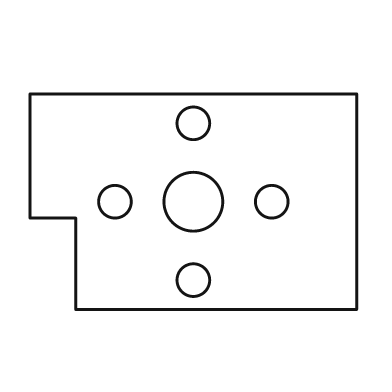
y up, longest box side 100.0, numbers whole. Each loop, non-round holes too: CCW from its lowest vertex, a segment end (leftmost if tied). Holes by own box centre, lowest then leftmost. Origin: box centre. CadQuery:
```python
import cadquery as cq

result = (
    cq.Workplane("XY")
    .moveTo(-36.0, -33.0)
    .lineTo(50.0, -33.0)
    .lineTo(50.0, 33.0)
    .lineTo(-50.0, 33.0)
    .lineTo(-50.0, -5.0)
    .lineTo(-36.0, -5.0)
    .close()
    .moveTo(0.0, -24.0)
    .circle(5.0)
    .moveTo(-24.0, 0.0)
    .circle(5.0)
    .moveTo(0.0, 0.0)
    .circle(9.0)
    .moveTo(24.0, 0.0)
    .circle(5.0)
    .moveTo(0.0, 24.0)
    .circle(5.0)
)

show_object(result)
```